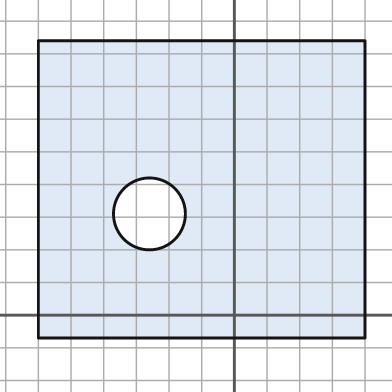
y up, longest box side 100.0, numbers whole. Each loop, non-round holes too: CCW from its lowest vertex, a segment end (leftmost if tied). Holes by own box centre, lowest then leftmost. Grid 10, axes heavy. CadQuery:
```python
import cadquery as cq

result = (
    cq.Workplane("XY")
    .moveTo(-60.0, -7.0)
    .lineTo(40.0, -7.0)
    .lineTo(40.0, 84.0)
    .lineTo(-60.0, 84.0)
    .close()
    .moveTo(-26.0, 31.0)
    .circle(11.0)
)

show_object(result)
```